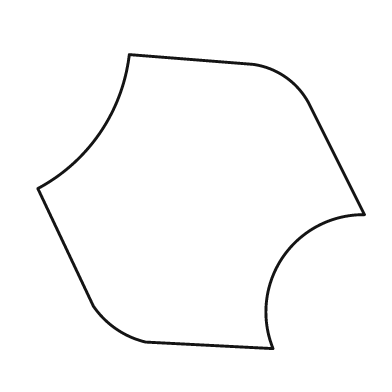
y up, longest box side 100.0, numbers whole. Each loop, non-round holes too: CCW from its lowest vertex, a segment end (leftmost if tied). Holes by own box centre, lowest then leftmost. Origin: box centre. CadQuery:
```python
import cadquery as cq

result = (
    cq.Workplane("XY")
    .moveTo(22.0, -45.0)
    .threePointArc((25.0, -17.0), (50.0, -4.0))
    .lineTo(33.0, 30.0)
    .threePointArc((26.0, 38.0), (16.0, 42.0))
    .lineTo(-22.0, 45.0)
    .threePointArc((-31.0, 21.0), (-50.0, 4.0))
    .lineTo(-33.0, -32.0)
    .threePointArc((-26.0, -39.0), (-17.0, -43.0))
    .close()
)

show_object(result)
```